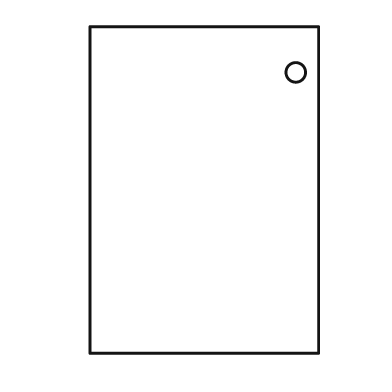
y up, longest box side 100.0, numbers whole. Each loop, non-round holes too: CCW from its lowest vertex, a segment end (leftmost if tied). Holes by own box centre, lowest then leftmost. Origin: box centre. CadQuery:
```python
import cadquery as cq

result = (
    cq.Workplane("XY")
    .moveTo(-35.0, -50.0)
    .lineTo(35.0, -50.0)
    .lineTo(35.0, 50.0)
    .lineTo(-35.0, 50.0)
    .close()
    .moveTo(28.0, 36.0)
    .circle(3.0)
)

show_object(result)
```